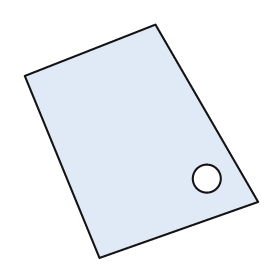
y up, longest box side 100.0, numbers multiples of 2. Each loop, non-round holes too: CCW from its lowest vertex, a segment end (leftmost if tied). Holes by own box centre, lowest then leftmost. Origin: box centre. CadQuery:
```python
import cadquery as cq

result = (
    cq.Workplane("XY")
    .moveTo(-18.0, -50.0)
    .lineTo(50.0, -26.0)
    .lineTo(6.0, 50.0)
    .lineTo(-50.0, 28.0)
    .close()
    .moveTo(28.0, -16.0)
    .circle(6.0)
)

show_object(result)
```